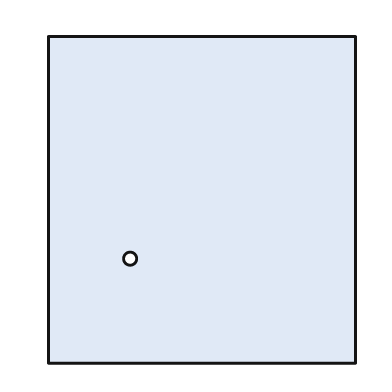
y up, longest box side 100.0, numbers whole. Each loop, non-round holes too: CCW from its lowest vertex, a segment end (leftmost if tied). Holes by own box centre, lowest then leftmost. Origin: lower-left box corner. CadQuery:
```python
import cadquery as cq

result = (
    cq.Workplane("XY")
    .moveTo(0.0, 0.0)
    .lineTo(94.0, 0.0)
    .lineTo(94.0, 100.0)
    .lineTo(0.0, 100.0)
    .close()
    .moveTo(25.0, 32.0)
    .circle(2.0)
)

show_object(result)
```